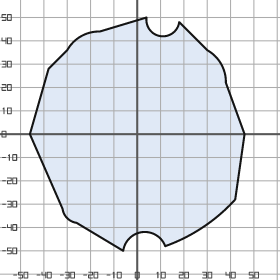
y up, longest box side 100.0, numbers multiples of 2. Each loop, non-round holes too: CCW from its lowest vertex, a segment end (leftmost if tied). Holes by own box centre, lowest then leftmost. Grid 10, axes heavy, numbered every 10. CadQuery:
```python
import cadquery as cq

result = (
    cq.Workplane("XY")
    .moveTo(-6.0, -50.0)
    .threePointArc((2.0, -42.0), (12.0, -48.0))
    .threePointArc((28.0, -40.0), (42.0, -28.0))
    .lineTo(46.0, 0.0)
    .lineTo(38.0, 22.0)
    .threePointArc((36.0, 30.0), (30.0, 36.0))
    .lineTo(18.0, 48.0)
    .threePointArc((10.0, 42.0), (4.0, 50.0))
    .lineTo(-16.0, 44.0)
    .threePointArc((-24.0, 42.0), (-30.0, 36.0))
    .lineTo(-38.0, 28.0)
    .lineTo(-46.0, 0.0)
    .lineTo(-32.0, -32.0)
    .threePointArc((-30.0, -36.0), (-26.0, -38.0))
    .close()
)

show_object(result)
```